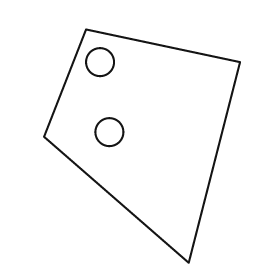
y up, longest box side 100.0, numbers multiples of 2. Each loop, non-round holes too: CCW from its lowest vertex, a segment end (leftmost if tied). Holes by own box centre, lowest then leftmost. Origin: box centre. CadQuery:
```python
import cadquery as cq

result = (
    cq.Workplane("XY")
    .moveTo(20.0, -50.0)
    .lineTo(42.0, 36.0)
    .lineTo(-24.0, 50.0)
    .lineTo(-42.0, 4.0)
    .close()
    .moveTo(-14.0, 6.0)
    .circle(6.0)
    .moveTo(-18.0, 36.0)
    .circle(6.0)
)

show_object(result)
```